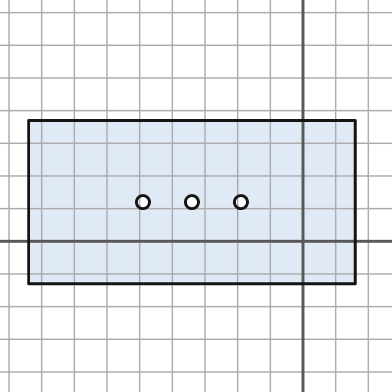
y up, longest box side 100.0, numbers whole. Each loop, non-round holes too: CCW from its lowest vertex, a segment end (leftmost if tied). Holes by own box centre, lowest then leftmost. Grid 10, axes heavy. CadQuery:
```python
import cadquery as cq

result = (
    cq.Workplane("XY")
    .moveTo(-84.0, -13.0)
    .lineTo(16.0, -13.0)
    .lineTo(16.0, 37.0)
    .lineTo(-84.0, 37.0)
    .close()
    .moveTo(-49.0, 12.0)
    .circle(2.0)
    .moveTo(-34.0, 12.0)
    .circle(2.0)
    .moveTo(-19.0, 12.0)
    .circle(2.0)
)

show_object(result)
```